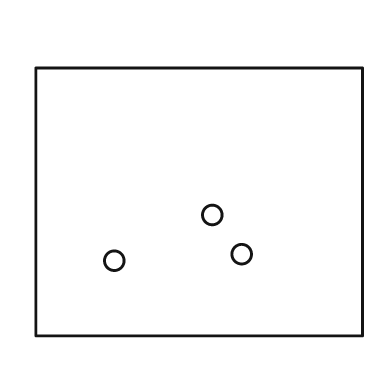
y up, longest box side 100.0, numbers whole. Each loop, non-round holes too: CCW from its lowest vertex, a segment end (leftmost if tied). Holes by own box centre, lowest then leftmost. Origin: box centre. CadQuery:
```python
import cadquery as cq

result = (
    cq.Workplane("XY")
    .moveTo(-50.0, -41.0)
    .lineTo(50.0, -41.0)
    .lineTo(50.0, 41.0)
    .lineTo(-50.0, 41.0)
    .close()
    .moveTo(-26.0, -18.0)
    .circle(3.0)
    .moveTo(13.0, -16.0)
    .circle(3.0)
    .moveTo(4.0, -4.0)
    .circle(3.0)
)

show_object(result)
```